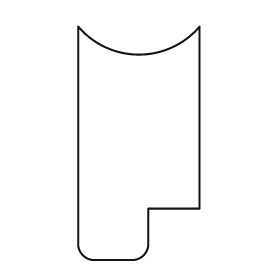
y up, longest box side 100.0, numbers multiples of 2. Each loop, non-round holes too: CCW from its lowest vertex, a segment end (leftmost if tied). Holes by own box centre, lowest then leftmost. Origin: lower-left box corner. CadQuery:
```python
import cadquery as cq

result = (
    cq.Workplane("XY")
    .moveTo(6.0, 0.0)
    .lineTo(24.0, 0.0)
    .threePointArc((28.0, 2.0), (30.0, 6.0))
    .lineTo(30.0, 22.0)
    .lineTo(52.0, 22.0)
    .lineTo(52.0, 100.0)
    .threePointArc((26.0, 88.0), (0.0, 100.0))
    .lineTo(0.0, 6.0)
    .threePointArc((2.0, 2.0), (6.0, 0.0))
    .close()
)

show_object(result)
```